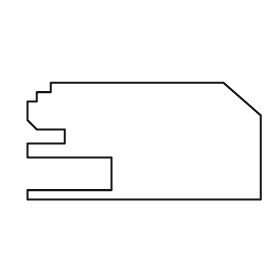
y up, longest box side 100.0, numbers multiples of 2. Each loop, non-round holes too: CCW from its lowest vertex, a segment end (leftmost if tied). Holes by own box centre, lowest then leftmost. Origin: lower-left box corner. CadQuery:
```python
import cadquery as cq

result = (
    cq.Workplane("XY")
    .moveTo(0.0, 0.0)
    .lineTo(100.0, 0.0)
    .lineTo(100.0, 36.0)
    .lineTo(84.0, 50.0)
    .lineTo(10.0, 50.0)
    .lineTo(10.0, 46.0)
    .lineTo(4.0, 46.0)
    .lineTo(4.0, 42.0)
    .lineTo(0.0, 42.0)
    .lineTo(0.0, 34.0)
    .lineTo(4.0, 30.0)
    .lineTo(16.0, 30.0)
    .lineTo(16.0, 24.0)
    .lineTo(0.0, 24.0)
    .lineTo(0.0, 18.0)
    .lineTo(36.0, 18.0)
    .lineTo(36.0, 4.0)
    .lineTo(0.0, 4.0)
    .close()
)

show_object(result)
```